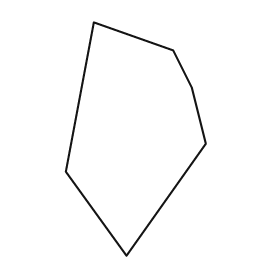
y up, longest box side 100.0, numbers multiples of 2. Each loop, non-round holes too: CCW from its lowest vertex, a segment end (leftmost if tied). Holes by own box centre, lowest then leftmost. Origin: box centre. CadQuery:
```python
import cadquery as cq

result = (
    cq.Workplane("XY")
    .moveTo(-4.0, -50.0)
    .lineTo(30.0, -2.0)
    .lineTo(24.0, 22.0)
    .lineTo(16.0, 38.0)
    .lineTo(-18.0, 50.0)
    .lineTo(-30.0, -14.0)
    .close()
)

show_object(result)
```